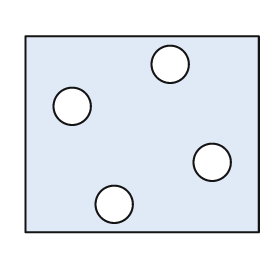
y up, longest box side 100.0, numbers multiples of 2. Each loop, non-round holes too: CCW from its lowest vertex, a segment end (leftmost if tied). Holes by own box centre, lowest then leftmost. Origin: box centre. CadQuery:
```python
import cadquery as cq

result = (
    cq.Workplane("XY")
    .moveTo(-50.0, -42.0)
    .lineTo(50.0, -42.0)
    .lineTo(50.0, 42.0)
    .lineTo(-50.0, 42.0)
    .close()
    .moveTo(-12.0, -30.0)
    .circle(8.0)
    .moveTo(30.0, -12.0)
    .circle(8.0)
    .moveTo(-30.0, 12.0)
    .circle(8.0)
    .moveTo(12.0, 30.0)
    .circle(8.0)
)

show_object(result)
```